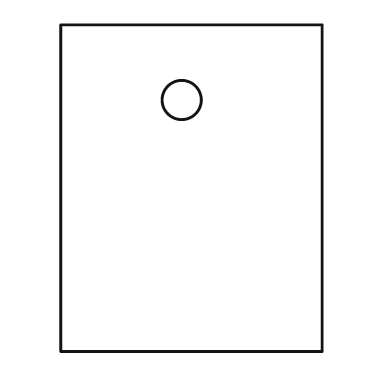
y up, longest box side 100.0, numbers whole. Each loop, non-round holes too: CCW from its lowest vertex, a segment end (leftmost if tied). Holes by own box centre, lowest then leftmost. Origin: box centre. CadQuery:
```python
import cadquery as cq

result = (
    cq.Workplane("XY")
    .moveTo(-40.0, -50.0)
    .lineTo(40.0, -50.0)
    .lineTo(40.0, 50.0)
    .lineTo(-40.0, 50.0)
    .close()
    .moveTo(-3.0, 27.0)
    .circle(6.0)
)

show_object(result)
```